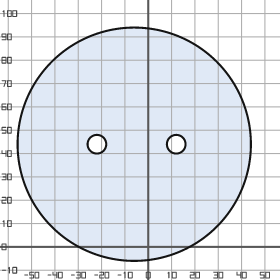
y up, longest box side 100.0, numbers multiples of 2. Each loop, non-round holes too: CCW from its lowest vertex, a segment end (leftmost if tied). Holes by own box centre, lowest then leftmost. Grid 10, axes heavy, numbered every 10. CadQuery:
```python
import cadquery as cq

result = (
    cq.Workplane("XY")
    .moveTo(-6.0, 44.0)
    .circle(50.0)
    .moveTo(-22.0, 44.0)
    .circle(4.0)
    .moveTo(12.0, 44.0)
    .circle(4.0)
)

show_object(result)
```